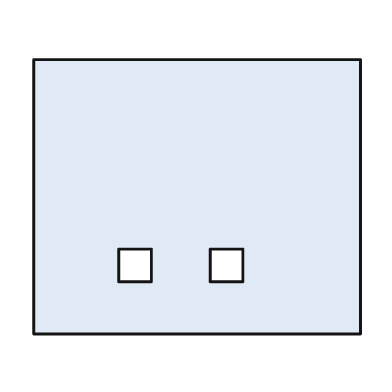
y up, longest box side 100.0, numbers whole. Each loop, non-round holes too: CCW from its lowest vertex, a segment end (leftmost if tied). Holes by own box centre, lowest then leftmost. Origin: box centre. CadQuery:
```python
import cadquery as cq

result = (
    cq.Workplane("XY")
    .moveTo(-50.0, -42.0)
    .lineTo(50.0, -42.0)
    .lineTo(50.0, 42.0)
    .lineTo(-50.0, 42.0)
    .close()
    .moveTo(-24.0, -26.0)
    .lineTo(-14.0, -26.0)
    .lineTo(-14.0, -16.0)
    .lineTo(-24.0, -16.0)
    .close()
    .moveTo(4.0, -26.0)
    .lineTo(14.0, -26.0)
    .lineTo(14.0, -16.0)
    .lineTo(4.0, -16.0)
    .close()
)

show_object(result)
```